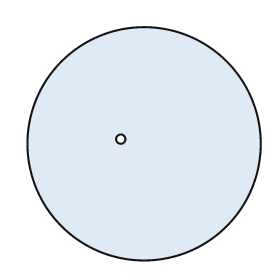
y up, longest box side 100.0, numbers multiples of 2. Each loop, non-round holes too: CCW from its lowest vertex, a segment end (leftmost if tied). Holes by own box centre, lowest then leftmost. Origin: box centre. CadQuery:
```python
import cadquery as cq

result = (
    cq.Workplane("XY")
    .moveTo(0.0, 0.0)
    .circle(50.0)
    .moveTo(-10.0, 2.0)
    .circle(2.0)
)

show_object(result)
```